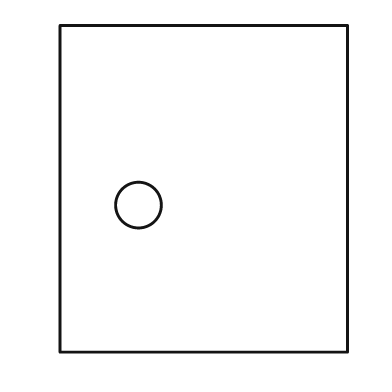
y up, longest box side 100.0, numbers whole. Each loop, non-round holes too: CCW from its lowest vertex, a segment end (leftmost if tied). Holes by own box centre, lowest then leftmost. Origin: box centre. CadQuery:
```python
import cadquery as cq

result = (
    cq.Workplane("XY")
    .moveTo(-44.0, -50.0)
    .lineTo(44.0, -50.0)
    .lineTo(44.0, 50.0)
    .lineTo(-44.0, 50.0)
    .close()
    .moveTo(-20.0, -5.0)
    .circle(7.0)
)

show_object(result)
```